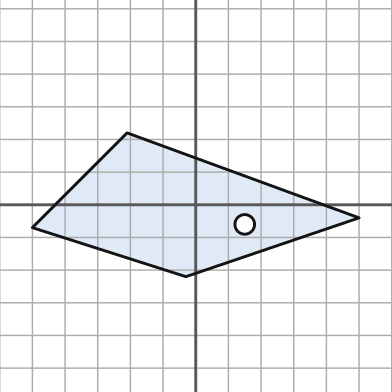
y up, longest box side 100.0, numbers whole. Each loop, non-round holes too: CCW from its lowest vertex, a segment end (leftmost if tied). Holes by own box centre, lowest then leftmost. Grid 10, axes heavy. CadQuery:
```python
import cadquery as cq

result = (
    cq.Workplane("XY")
    .moveTo(-3.0, -22.0)
    .lineTo(50.0, -4.0)
    .lineTo(-21.0, 22.0)
    .lineTo(-50.0, -7.0)
    .close()
    .moveTo(15.0, -6.0)
    .circle(3.0)
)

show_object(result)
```